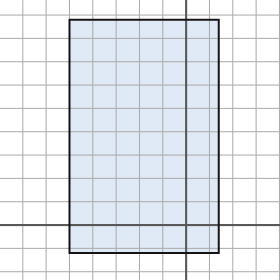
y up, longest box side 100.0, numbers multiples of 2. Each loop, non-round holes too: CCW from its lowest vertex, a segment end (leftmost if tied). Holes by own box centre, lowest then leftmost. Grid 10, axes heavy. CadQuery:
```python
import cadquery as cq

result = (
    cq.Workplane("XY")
    .moveTo(-50.0, -12.0)
    .lineTo(14.0, -12.0)
    .lineTo(14.0, 88.0)
    .lineTo(-50.0, 88.0)
    .close()
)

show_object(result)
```